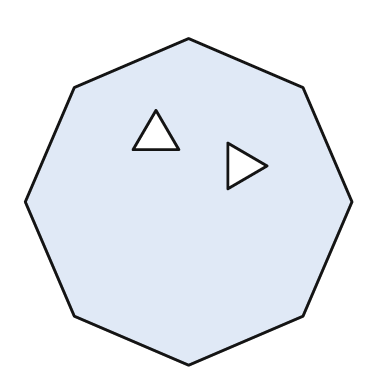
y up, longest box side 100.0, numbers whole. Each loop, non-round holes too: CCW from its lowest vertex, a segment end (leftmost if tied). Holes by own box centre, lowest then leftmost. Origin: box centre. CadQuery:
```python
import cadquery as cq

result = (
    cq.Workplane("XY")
    .moveTo(0.0, -50.0)
    .lineTo(35.0, -35.0)
    .lineTo(50.0, 0.0)
    .lineTo(35.0, 35.0)
    .lineTo(0.0, 50.0)
    .lineTo(-35.0, 35.0)
    .lineTo(-50.0, 0.0)
    .lineTo(-35.0, -35.0)
    .close()
    .moveTo(12.0, 4.0)
    .lineTo(24.0, 11.0)
    .lineTo(12.0, 18.0)
    .close()
    .moveTo(-17.0, 16.0)
    .lineTo(-3.0, 16.0)
    .lineTo(-10.0, 28.0)
    .close()
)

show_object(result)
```